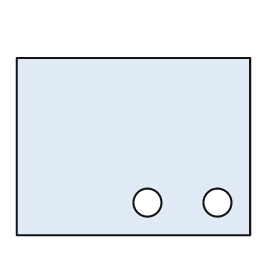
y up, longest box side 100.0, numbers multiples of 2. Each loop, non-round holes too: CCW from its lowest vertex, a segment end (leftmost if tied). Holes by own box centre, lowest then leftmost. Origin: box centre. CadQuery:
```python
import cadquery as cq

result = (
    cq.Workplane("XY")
    .moveTo(-50.0, -38.0)
    .lineTo(50.0, -38.0)
    .lineTo(50.0, 38.0)
    .lineTo(-50.0, 38.0)
    .close()
    .moveTo(6.0, -24.0)
    .circle(6.0)
    .moveTo(36.0, -24.0)
    .circle(6.0)
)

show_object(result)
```